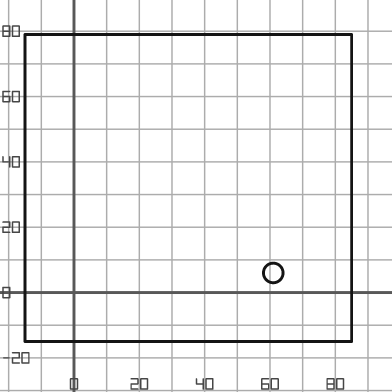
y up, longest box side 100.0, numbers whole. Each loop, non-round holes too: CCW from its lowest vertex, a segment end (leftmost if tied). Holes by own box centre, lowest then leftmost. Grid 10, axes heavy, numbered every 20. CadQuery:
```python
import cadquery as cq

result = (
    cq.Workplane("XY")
    .moveTo(-15.0, -15.0)
    .lineTo(85.0, -15.0)
    .lineTo(85.0, 79.0)
    .lineTo(-15.0, 79.0)
    .close()
    .moveTo(61.0, 6.0)
    .circle(3.0)
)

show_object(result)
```